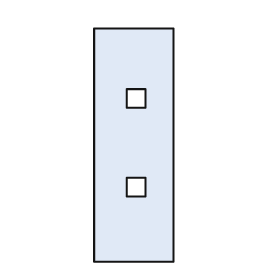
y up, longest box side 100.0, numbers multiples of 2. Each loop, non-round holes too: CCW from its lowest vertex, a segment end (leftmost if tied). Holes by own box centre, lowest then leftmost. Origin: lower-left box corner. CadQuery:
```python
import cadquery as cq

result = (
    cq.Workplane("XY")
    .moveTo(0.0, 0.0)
    .lineTo(34.0, 0.0)
    .lineTo(34.0, 100.0)
    .lineTo(0.0, 100.0)
    .close()
    .moveTo(14.0, 28.0)
    .lineTo(22.0, 28.0)
    .lineTo(22.0, 36.0)
    .lineTo(14.0, 36.0)
    .close()
    .moveTo(14.0, 66.0)
    .lineTo(22.0, 66.0)
    .lineTo(22.0, 74.0)
    .lineTo(14.0, 74.0)
    .close()
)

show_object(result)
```